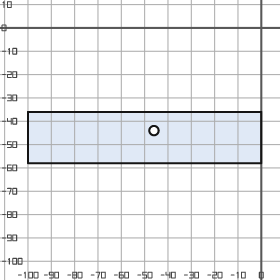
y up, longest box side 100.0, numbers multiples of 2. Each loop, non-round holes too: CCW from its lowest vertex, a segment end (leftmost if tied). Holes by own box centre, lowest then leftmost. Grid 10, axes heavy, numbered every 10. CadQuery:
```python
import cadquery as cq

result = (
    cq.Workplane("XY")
    .moveTo(-100.0, -58.0)
    .lineTo(0.0, -58.0)
    .lineTo(0.0, -36.0)
    .lineTo(-100.0, -36.0)
    .close()
    .moveTo(-46.0, -44.0)
    .circle(2.0)
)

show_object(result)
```